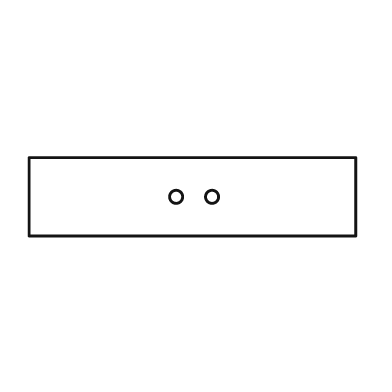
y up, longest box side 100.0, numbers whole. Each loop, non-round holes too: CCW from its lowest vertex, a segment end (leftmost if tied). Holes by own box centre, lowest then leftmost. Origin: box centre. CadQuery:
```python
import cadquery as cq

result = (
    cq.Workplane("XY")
    .moveTo(-50.0, -12.0)
    .lineTo(50.0, -12.0)
    .lineTo(50.0, 12.0)
    .lineTo(-50.0, 12.0)
    .close()
    .moveTo(-5.0, 0.0)
    .circle(2.0)
    .moveTo(6.0, 0.0)
    .circle(2.0)
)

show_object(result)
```